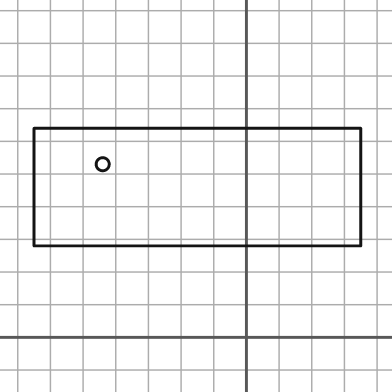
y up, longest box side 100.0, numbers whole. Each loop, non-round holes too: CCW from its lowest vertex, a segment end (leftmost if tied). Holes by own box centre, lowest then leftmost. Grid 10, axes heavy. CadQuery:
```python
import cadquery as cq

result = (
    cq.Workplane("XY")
    .moveTo(-65.0, 28.0)
    .lineTo(35.0, 28.0)
    .lineTo(35.0, 64.0)
    .lineTo(-65.0, 64.0)
    .close()
    .moveTo(-44.0, 53.0)
    .circle(2.0)
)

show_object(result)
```